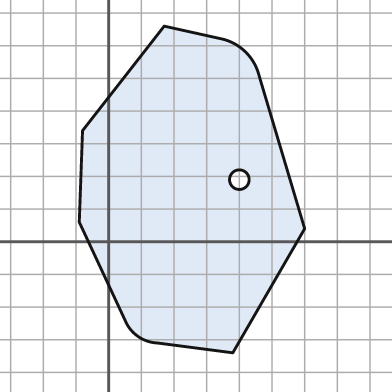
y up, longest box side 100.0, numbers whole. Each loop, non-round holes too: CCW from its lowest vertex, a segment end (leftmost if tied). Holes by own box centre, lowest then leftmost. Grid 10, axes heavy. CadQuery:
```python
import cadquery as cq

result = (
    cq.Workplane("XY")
    .moveTo(38.0, -34.0)
    .lineTo(60.0, 4.0)
    .lineTo(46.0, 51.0)
    .threePointArc((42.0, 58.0), (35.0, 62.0))
    .lineTo(17.0, 66.0)
    .lineTo(-8.0, 34.0)
    .lineTo(-9.0, 6.0)
    .lineTo(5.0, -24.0)
    .threePointArc((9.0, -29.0), (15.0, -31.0))
    .close()
    .moveTo(40.0, 19.0)
    .circle(3.0)
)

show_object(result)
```